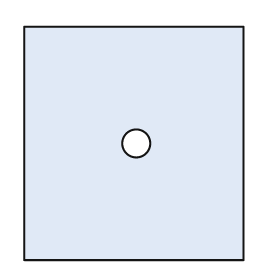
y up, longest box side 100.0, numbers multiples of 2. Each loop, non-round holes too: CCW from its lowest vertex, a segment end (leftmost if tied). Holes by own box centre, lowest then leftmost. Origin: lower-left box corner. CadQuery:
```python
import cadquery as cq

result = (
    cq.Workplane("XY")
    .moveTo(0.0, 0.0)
    .lineTo(94.0, 0.0)
    .lineTo(94.0, 100.0)
    .lineTo(0.0, 100.0)
    .close()
    .moveTo(48.0, 50.0)
    .circle(6.0)
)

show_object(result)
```